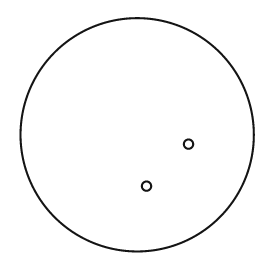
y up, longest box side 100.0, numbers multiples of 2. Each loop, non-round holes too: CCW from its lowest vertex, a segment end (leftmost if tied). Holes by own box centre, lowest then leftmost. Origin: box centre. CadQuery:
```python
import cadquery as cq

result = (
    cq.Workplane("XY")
    .moveTo(0.0, 0.0)
    .circle(50.0)
    .moveTo(4.0, -22.0)
    .circle(2.0)
    .moveTo(22.0, -4.0)
    .circle(2.0)
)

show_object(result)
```